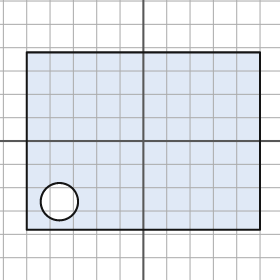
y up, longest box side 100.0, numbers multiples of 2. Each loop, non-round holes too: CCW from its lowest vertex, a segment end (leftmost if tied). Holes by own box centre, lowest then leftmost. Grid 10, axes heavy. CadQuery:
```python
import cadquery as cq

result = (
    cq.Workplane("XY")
    .moveTo(-50.0, -38.0)
    .lineTo(50.0, -38.0)
    .lineTo(50.0, 38.0)
    .lineTo(-50.0, 38.0)
    .close()
    .moveTo(-36.0, -26.0)
    .circle(8.0)
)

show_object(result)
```